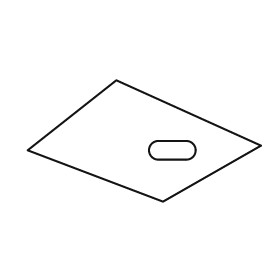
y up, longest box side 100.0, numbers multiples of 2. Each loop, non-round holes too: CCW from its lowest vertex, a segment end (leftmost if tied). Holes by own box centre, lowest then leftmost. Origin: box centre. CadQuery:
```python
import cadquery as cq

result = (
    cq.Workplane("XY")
    .moveTo(8.0, -26.0)
    .lineTo(50.0, -2.0)
    .lineTo(-12.0, 26.0)
    .lineTo(-50.0, -4.0)
    .close()
    .moveTo(6.0, -8.0)
    .lineTo(18.0, -8.0)
    .threePointArc((22.0, -4.0), (18.0, 0.0))
    .lineTo(6.0, 0.0)
    .threePointArc((2.0, -4.0), (6.0, -8.0))
    .close()
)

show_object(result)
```